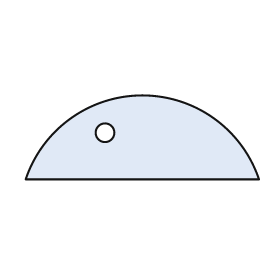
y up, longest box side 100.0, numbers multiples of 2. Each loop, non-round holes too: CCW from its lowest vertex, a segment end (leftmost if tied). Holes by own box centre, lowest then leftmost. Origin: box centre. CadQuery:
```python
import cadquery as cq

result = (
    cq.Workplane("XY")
    .moveTo(-50.0, -18.0)
    .lineTo(50.0, -18.0)
    .threePointArc((0.0, 18.0), (-50.0, -18.0))
    .close()
    .moveTo(-16.0, 2.0)
    .circle(4.0)
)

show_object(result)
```